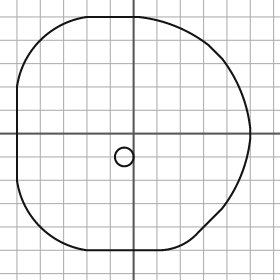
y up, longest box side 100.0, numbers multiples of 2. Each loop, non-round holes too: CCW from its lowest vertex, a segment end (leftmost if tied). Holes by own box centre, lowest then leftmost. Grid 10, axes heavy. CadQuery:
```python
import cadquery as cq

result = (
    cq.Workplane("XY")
    .moveTo(-20.0, -50.0)
    .lineTo(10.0, -50.0)
    .threePointArc((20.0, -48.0), (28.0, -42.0))
    .lineTo(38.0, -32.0)
    .threePointArc((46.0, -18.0), (50.0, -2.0))
    .lineTo(50.0, 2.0)
    .threePointArc((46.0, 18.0), (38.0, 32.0))
    .lineTo(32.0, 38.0)
    .threePointArc((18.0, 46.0), (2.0, 50.0))
    .lineTo(-20.0, 50.0)
    .threePointArc((-40.0, 40.0), (-50.0, 20.0))
    .lineTo(-50.0, -20.0)
    .threePointArc((-40.0, -40.0), (-20.0, -50.0))
    .close()
    .moveTo(-4.0, -10.0)
    .circle(4.0)
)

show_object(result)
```